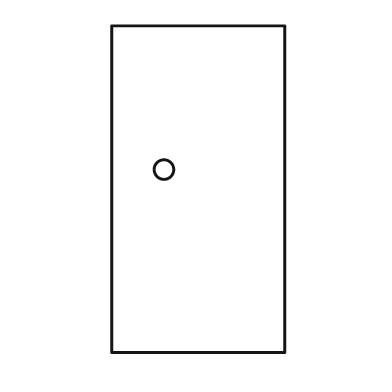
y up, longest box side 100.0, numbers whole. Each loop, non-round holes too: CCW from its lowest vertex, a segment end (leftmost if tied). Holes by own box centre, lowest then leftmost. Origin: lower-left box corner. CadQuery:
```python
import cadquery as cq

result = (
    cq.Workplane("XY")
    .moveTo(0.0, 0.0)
    .lineTo(53.0, 0.0)
    .lineTo(53.0, 100.0)
    .lineTo(0.0, 100.0)
    .close()
    .moveTo(16.0, 56.0)
    .circle(3.0)
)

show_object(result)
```